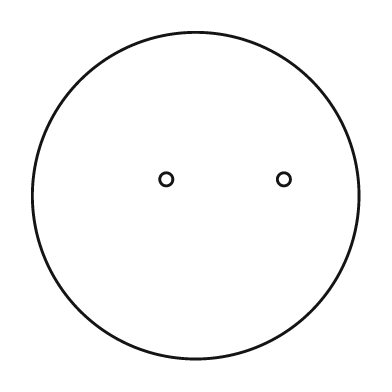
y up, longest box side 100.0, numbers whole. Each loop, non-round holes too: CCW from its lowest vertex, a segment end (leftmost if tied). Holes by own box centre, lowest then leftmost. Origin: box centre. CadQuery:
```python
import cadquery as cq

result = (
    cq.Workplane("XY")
    .moveTo(0.0, 0.0)
    .circle(50.0)
    .moveTo(-9.0, 5.0)
    .circle(2.0)
    .moveTo(27.0, 5.0)
    .circle(2.0)
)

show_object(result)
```